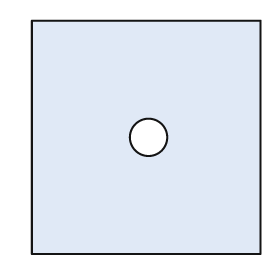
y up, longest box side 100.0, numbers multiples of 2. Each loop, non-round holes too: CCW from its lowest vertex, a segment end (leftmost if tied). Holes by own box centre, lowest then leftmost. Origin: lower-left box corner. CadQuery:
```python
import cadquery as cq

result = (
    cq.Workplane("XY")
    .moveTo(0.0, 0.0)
    .lineTo(98.0, 0.0)
    .lineTo(98.0, 100.0)
    .lineTo(0.0, 100.0)
    .close()
    .moveTo(50.0, 50.0)
    .circle(8.0)
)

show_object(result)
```